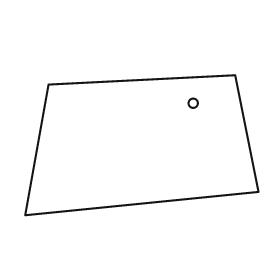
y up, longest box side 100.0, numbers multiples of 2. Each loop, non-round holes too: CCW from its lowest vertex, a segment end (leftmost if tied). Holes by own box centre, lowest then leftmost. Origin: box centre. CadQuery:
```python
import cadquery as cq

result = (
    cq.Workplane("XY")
    .moveTo(-50.0, -30.0)
    .lineTo(50.0, -20.0)
    .lineTo(40.0, 30.0)
    .lineTo(-40.0, 26.0)
    .close()
    .moveTo(22.0, 18.0)
    .circle(2.0)
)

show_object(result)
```